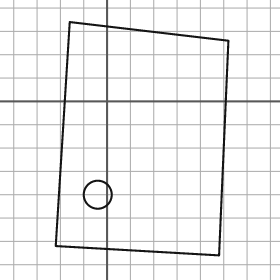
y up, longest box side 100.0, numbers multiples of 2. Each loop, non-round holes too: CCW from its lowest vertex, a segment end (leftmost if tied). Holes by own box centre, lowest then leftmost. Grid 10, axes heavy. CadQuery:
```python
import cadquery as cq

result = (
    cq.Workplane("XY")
    .moveTo(48.0, -66.0)
    .lineTo(52.0, 26.0)
    .lineTo(-16.0, 34.0)
    .lineTo(-22.0, -62.0)
    .close()
    .moveTo(-4.0, -40.0)
    .circle(6.0)
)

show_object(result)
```